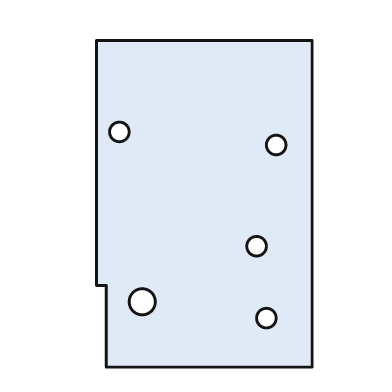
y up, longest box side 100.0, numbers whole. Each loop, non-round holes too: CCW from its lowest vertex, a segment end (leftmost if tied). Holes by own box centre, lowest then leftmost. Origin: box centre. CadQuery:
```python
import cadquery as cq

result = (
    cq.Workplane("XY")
    .moveTo(-30.0, -50.0)
    .lineTo(33.0, -50.0)
    .lineTo(33.0, 50.0)
    .lineTo(-33.0, 50.0)
    .lineTo(-33.0, -25.0)
    .lineTo(-30.0, -25.0)
    .close()
    .moveTo(19.0, -35.0)
    .circle(3.0)
    .moveTo(-19.0, -30.0)
    .circle(4.0)
    .moveTo(16.0, -13.0)
    .circle(3.0)
    .moveTo(22.0, 18.0)
    .circle(3.0)
    .moveTo(-26.0, 22.0)
    .circle(3.0)
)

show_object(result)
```